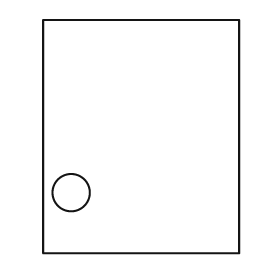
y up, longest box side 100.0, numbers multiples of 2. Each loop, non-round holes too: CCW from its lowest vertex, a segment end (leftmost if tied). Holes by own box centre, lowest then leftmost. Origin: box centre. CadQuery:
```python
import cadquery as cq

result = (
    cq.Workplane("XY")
    .moveTo(-42.0, -50.0)
    .lineTo(42.0, -50.0)
    .lineTo(42.0, 50.0)
    .lineTo(-42.0, 50.0)
    .close()
    .moveTo(-30.0, -24.0)
    .circle(8.0)
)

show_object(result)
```